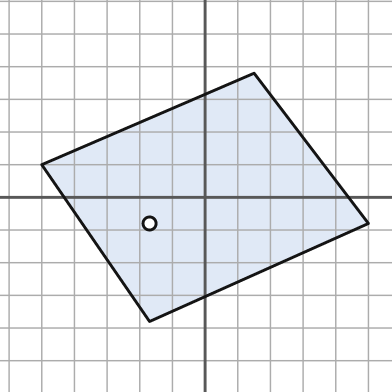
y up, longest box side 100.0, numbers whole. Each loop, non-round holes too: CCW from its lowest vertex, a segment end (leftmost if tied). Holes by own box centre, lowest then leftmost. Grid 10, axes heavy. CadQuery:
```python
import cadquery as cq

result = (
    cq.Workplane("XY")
    .moveTo(-17.0, -38.0)
    .lineTo(50.0, -8.0)
    .lineTo(15.0, 38.0)
    .lineTo(-50.0, 10.0)
    .close()
    .moveTo(-17.0, -8.0)
    .circle(2.0)
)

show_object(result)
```